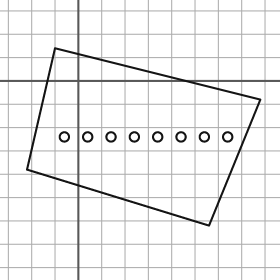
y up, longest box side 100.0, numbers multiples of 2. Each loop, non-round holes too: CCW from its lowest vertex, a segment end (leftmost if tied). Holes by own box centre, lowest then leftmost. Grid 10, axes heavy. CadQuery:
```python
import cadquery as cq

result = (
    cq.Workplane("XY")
    .moveTo(56.0, -62.0)
    .lineTo(78.0, -8.0)
    .lineTo(-10.0, 14.0)
    .lineTo(-22.0, -38.0)
    .close()
    .moveTo(-6.0, -24.0)
    .circle(2.0)
    .moveTo(4.0, -24.0)
    .circle(2.0)
    .moveTo(14.0, -24.0)
    .circle(2.0)
    .moveTo(24.0, -24.0)
    .circle(2.0)
    .moveTo(34.0, -24.0)
    .circle(2.0)
    .moveTo(44.0, -24.0)
    .circle(2.0)
    .moveTo(54.0, -24.0)
    .circle(2.0)
    .moveTo(64.0, -24.0)
    .circle(2.0)
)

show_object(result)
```